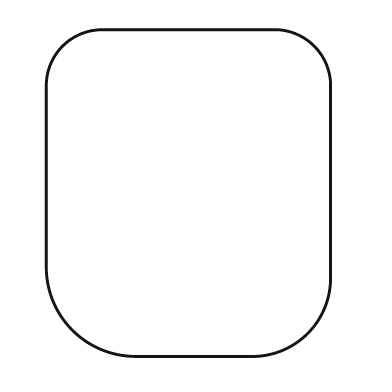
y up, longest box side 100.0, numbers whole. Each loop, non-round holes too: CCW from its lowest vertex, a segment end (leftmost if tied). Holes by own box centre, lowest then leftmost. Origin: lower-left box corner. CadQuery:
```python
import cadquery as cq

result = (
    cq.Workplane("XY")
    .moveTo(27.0, 0.0)
    .lineTo(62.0, 0.0)
    .threePointArc((80.0, 7.0), (87.0, 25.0))
    .lineTo(87.0, 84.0)
    .threePointArc((82.0, 95.0), (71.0, 100.0))
    .lineTo(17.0, 100.0)
    .threePointArc((5.0, 95.0), (0.0, 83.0))
    .lineTo(0.0, 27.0)
    .threePointArc((8.0, 8.0), (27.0, 0.0))
    .close()
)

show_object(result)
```